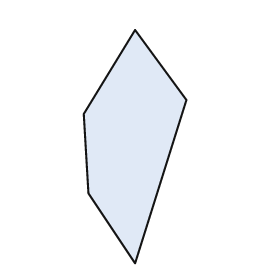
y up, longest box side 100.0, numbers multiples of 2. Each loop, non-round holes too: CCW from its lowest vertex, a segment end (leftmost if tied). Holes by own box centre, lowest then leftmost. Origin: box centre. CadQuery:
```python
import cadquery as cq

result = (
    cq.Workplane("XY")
    .moveTo(0.0, -50.0)
    .lineTo(22.0, 20.0)
    .lineTo(0.0, 50.0)
    .lineTo(-22.0, 14.0)
    .lineTo(-20.0, -20.0)
    .close()
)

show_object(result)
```